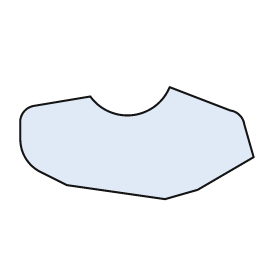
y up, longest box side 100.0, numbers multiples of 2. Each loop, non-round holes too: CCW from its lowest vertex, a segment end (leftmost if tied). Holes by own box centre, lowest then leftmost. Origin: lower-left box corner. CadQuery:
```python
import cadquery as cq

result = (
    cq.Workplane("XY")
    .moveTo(62.0, 0.0)
    .lineTo(76.0, 4.0)
    .lineTo(100.0, 18.0)
    .lineTo(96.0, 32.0)
    .threePointArc((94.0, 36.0), (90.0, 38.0))
    .lineTo(64.0, 48.0)
    .threePointArc((48.0, 36.0), (30.0, 44.0))
    .lineTo(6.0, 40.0)
    .threePointArc((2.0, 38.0), (0.0, 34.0))
    .lineTo(0.0, 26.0)
    .threePointArc((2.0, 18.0), (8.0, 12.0))
    .lineTo(20.0, 6.0)
    .close()
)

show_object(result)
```